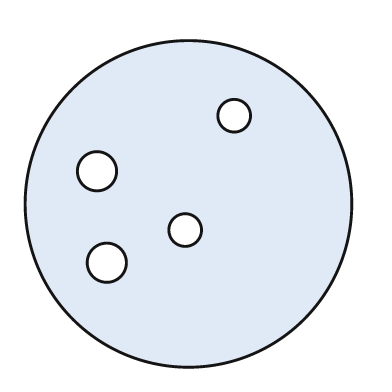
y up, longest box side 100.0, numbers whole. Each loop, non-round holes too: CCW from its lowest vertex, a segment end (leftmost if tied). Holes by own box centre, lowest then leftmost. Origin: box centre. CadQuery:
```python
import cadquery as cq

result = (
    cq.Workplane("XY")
    .moveTo(0.0, 0.0)
    .circle(50.0)
    .moveTo(-25.0, -18.0)
    .circle(6.0)
    .moveTo(-1.0, -8.0)
    .circle(5.0)
    .moveTo(-28.0, 10.0)
    .circle(6.0)
    .moveTo(14.0, 27.0)
    .circle(5.0)
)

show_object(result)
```